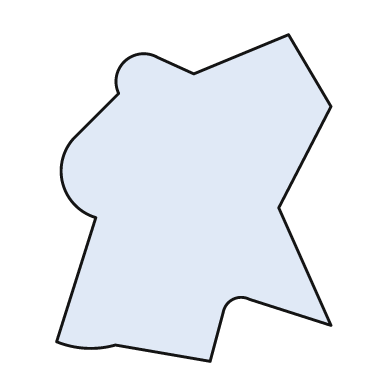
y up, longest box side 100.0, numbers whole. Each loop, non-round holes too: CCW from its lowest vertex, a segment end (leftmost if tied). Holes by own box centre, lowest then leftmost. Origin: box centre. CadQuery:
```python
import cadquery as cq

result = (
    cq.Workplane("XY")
    .moveTo(5.0, -50.0)
    .lineTo(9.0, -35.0)
    .threePointArc((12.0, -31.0), (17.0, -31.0))
    .lineTo(42.0, -39.0)
    .lineTo(26.0, -3.0)
    .lineTo(42.0, 28.0)
    .lineTo(29.0, 50.0)
    .lineTo(0.0, 38.0)
    .lineTo(-11.0, 43.0)
    .threePointArc((-21.0, 42.0), (-23.0, 32.0))
    .lineTo(-37.0, 18.0)
    .threePointArc((-40.0, 4.0), (-30.0, -6.0))
    .lineTo(-42.0, -44.0)
    .threePointArc((-33.0, -46.0), (-24.0, -45.0))
    .close()
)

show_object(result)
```